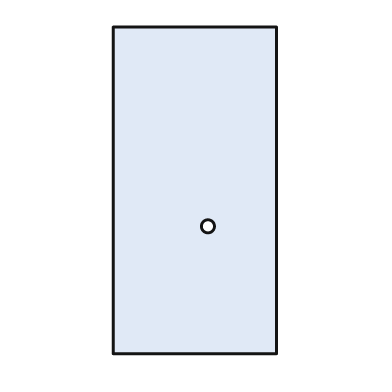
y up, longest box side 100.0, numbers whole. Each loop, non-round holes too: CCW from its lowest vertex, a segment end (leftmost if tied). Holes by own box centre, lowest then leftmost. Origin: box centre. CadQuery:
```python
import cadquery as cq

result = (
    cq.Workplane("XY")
    .moveTo(-25.0, -50.0)
    .lineTo(25.0, -50.0)
    .lineTo(25.0, 50.0)
    .lineTo(-25.0, 50.0)
    .close()
    .moveTo(4.0, -11.0)
    .circle(2.0)
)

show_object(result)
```